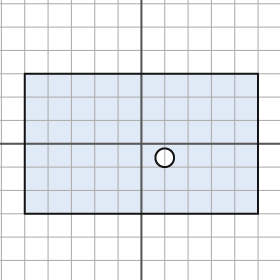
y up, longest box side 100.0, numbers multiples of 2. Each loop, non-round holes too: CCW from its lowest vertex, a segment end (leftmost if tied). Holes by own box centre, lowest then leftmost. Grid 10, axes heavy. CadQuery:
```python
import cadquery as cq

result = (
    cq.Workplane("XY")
    .moveTo(-50.0, -30.0)
    .lineTo(50.0, -30.0)
    .lineTo(50.0, 30.0)
    .lineTo(-50.0, 30.0)
    .close()
    .moveTo(10.0, -6.0)
    .circle(4.0)
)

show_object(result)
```